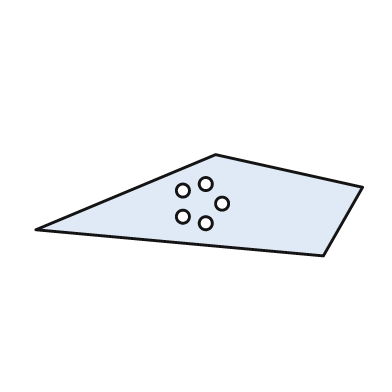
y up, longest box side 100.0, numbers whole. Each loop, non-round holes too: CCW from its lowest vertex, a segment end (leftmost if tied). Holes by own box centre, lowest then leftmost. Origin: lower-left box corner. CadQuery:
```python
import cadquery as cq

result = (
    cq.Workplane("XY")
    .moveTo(88.0, 0.0)
    .lineTo(100.0, 21.0)
    .lineTo(55.0, 31.0)
    .lineTo(0.0, 8.0)
    .close()
    .moveTo(52.0, 10.0)
    .circle(2.0)
    .moveTo(45.0, 12.0)
    .circle(2.0)
    .moveTo(57.0, 16.0)
    .circle(2.0)
    .moveTo(45.0, 20.0)
    .circle(2.0)
    .moveTo(52.0, 22.0)
    .circle(2.0)
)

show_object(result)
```